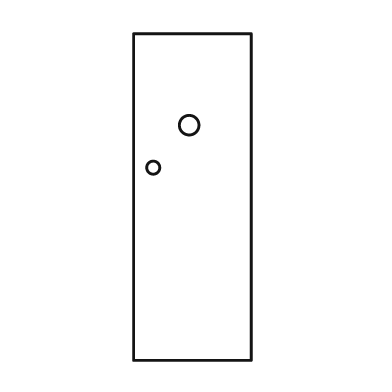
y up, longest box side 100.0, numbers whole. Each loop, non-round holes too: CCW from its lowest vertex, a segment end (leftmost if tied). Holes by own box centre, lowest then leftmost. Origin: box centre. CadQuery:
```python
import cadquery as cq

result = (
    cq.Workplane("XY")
    .moveTo(-18.0, -50.0)
    .lineTo(18.0, -50.0)
    .lineTo(18.0, 50.0)
    .lineTo(-18.0, 50.0)
    .close()
    .moveTo(-12.0, 9.0)
    .circle(2.0)
    .moveTo(-1.0, 22.0)
    .circle(3.0)
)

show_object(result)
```